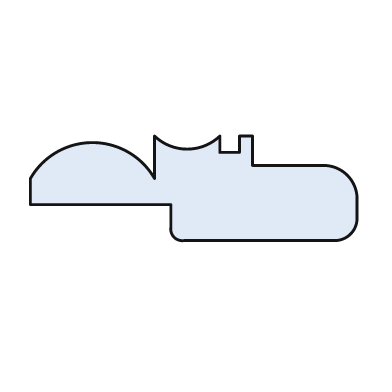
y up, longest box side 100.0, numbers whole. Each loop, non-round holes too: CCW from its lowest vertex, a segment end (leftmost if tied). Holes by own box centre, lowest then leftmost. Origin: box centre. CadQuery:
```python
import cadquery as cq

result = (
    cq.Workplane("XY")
    .moveTo(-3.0, -16.0)
    .lineTo(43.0, -16.0)
    .threePointArc((48.0, -14.0), (50.0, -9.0))
    .lineTo(50.0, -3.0)
    .threePointArc((47.0, 4.0), (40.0, 7.0))
    .lineTo(18.0, 7.0)
    .lineTo(18.0, 16.0)
    .lineTo(14.0, 16.0)
    .lineTo(14.0, 11.0)
    .lineTo(8.0, 11.0)
    .lineTo(8.0, 16.0)
    .threePointArc((-2.0, 12.0), (-12.0, 16.0))
    .lineTo(-12.0, 3.0)
    .threePointArc((-31.0, 14.0), (-50.0, 3.0))
    .lineTo(-50.0, -5.0)
    .lineTo(-7.0, -5.0)
    .lineTo(-7.0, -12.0)
    .threePointArc((-6.0, -15.0), (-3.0, -16.0))
    .close()
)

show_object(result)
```